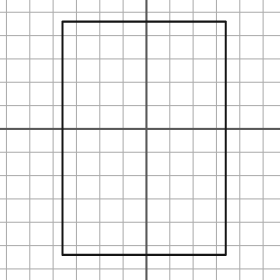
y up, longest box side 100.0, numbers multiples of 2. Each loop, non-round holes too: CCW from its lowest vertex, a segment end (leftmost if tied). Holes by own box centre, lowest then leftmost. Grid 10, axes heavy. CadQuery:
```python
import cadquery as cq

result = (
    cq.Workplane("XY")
    .moveTo(-36.0, -54.0)
    .lineTo(34.0, -54.0)
    .lineTo(34.0, 46.0)
    .lineTo(-36.0, 46.0)
    .close()
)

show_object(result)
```